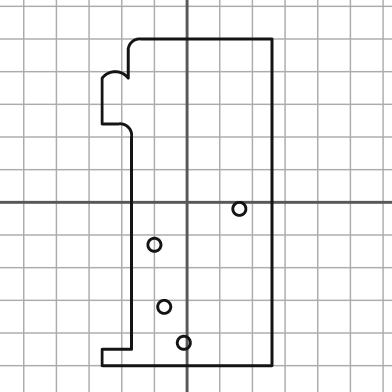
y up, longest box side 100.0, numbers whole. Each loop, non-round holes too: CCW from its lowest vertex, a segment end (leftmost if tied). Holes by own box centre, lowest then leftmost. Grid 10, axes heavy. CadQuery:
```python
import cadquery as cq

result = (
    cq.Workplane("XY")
    .moveTo(-26.0, -50.0)
    .lineTo(26.0, -50.0)
    .lineTo(26.0, 50.0)
    .lineTo(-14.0, 50.0)
    .threePointArc((-17.0, 49.0), (-18.0, 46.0))
    .lineTo(-18.0, 38.0)
    .threePointArc((-22.0, 40.0), (-26.0, 38.0))
    .lineTo(-26.0, 24.0)
    .lineTo(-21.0, 24.0)
    .threePointArc((-18.0, 23.0), (-17.0, 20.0))
    .lineTo(-17.0, -45.0)
    .lineTo(-26.0, -45.0)
    .close()
    .moveTo(-1.0, -43.0)
    .circle(2.0)
    .moveTo(-7.0, -32.0)
    .circle(2.0)
    .moveTo(-10.0, -13.0)
    .circle(2.0)
    .moveTo(16.0, -2.0)
    .circle(2.0)
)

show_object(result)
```